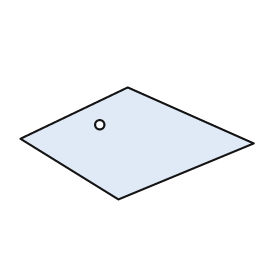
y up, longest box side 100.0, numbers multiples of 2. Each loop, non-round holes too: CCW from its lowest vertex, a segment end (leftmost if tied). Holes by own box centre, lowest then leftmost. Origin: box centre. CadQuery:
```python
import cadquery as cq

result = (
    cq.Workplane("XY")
    .moveTo(-8.0, -24.0)
    .lineTo(50.0, 0.0)
    .lineTo(-4.0, 24.0)
    .lineTo(-50.0, 2.0)
    .close()
    .moveTo(-16.0, 8.0)
    .circle(2.0)
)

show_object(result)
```